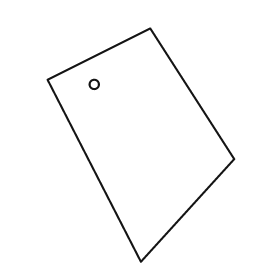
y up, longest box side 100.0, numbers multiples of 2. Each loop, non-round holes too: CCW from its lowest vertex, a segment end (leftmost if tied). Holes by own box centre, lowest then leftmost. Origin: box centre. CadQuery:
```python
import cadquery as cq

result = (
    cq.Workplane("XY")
    .moveTo(0.0, -50.0)
    .lineTo(40.0, -6.0)
    .lineTo(4.0, 50.0)
    .lineTo(-40.0, 28.0)
    .close()
    .moveTo(-20.0, 26.0)
    .circle(2.0)
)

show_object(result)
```